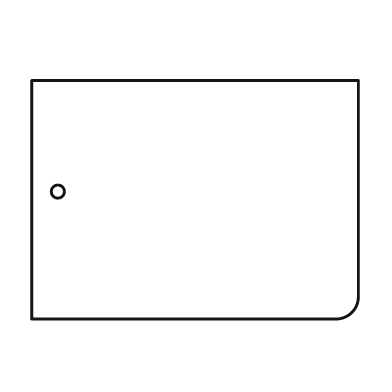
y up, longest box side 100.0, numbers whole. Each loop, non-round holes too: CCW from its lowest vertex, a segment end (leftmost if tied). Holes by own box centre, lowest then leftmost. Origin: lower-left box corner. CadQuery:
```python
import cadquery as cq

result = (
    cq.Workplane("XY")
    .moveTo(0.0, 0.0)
    .lineTo(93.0, 0.0)
    .threePointArc((98.0, 2.0), (100.0, 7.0))
    .lineTo(100.0, 73.0)
    .lineTo(0.0, 73.0)
    .close()
    .moveTo(8.0, 39.0)
    .circle(2.0)
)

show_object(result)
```